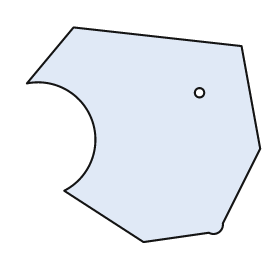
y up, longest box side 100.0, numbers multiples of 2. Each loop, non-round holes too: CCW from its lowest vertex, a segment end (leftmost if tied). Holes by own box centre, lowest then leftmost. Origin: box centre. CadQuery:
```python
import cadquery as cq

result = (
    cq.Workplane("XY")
    .moveTo(0.0, -46.0)
    .lineTo(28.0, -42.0)
    .threePointArc((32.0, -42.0), (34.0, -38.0))
    .lineTo(50.0, -6.0)
    .lineTo(42.0, 38.0)
    .lineTo(-30.0, 46.0)
    .lineTo(-50.0, 22.0)
    .threePointArc((-22.0, 6.0), (-34.0, -24.0))
    .close()
    .moveTo(24.0, 18.0)
    .circle(2.0)
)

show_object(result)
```